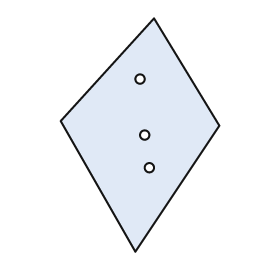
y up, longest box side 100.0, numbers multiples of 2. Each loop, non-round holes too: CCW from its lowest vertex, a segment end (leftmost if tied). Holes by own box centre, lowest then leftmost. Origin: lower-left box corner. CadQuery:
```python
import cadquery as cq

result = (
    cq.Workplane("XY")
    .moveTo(32.0, 0.0)
    .lineTo(68.0, 54.0)
    .lineTo(40.0, 100.0)
    .lineTo(0.0, 56.0)
    .close()
    .moveTo(38.0, 36.0)
    .circle(2.0)
    .moveTo(36.0, 50.0)
    .circle(2.0)
    .moveTo(34.0, 74.0)
    .circle(2.0)
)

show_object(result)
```